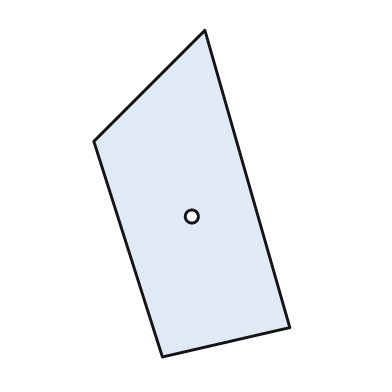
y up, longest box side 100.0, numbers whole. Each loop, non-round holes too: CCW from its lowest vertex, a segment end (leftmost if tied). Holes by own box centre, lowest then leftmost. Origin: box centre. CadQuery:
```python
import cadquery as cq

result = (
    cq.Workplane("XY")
    .moveTo(-9.0, -50.0)
    .lineTo(30.0, -41.0)
    .lineTo(4.0, 50.0)
    .lineTo(-30.0, 16.0)
    .close()
    .moveTo(0.0, -7.0)
    .circle(2.0)
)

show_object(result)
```